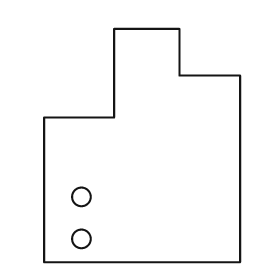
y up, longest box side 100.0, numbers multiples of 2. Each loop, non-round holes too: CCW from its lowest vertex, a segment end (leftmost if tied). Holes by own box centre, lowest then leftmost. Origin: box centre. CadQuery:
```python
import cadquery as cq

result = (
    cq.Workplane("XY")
    .moveTo(-42.0, -50.0)
    .lineTo(42.0, -50.0)
    .lineTo(42.0, 30.0)
    .lineTo(16.0, 30.0)
    .lineTo(16.0, 50.0)
    .lineTo(-12.0, 50.0)
    .lineTo(-12.0, 12.0)
    .lineTo(-42.0, 12.0)
    .close()
    .moveTo(-26.0, -40.0)
    .circle(4.0)
    .moveTo(-26.0, -22.0)
    .circle(4.0)
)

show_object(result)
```